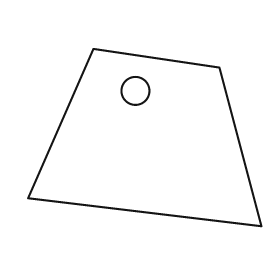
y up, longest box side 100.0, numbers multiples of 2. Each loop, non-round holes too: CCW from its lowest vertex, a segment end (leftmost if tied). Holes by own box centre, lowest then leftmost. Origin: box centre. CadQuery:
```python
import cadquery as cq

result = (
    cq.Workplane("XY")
    .moveTo(50.0, -38.0)
    .lineTo(32.0, 30.0)
    .lineTo(-22.0, 38.0)
    .lineTo(-50.0, -26.0)
    .close()
    .moveTo(-4.0, 20.0)
    .circle(6.0)
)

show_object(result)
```